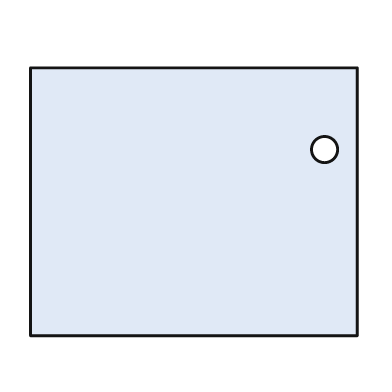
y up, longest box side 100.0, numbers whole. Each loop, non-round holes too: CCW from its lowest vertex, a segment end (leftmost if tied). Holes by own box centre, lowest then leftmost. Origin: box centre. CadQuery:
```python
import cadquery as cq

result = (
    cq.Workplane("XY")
    .moveTo(-50.0, -41.0)
    .lineTo(50.0, -41.0)
    .lineTo(50.0, 41.0)
    .lineTo(-50.0, 41.0)
    .close()
    .moveTo(40.0, 16.0)
    .circle(4.0)
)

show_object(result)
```